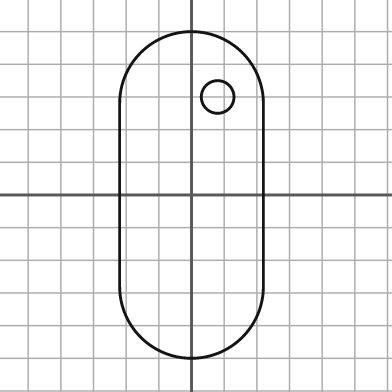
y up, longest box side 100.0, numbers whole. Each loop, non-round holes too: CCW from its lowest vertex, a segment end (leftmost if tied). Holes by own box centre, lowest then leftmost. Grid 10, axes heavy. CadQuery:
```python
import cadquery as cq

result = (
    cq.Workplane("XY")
    .moveTo(-22.0, -28.0)
    .threePointArc((0.0, -50.0), (22.0, -28.0))
    .lineTo(22.0, 28.0)
    .threePointArc((0.0, 50.0), (-22.0, 28.0))
    .close()
    .moveTo(8.0, 30.0)
    .circle(5.0)
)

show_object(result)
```